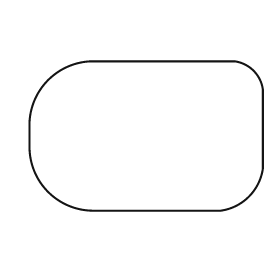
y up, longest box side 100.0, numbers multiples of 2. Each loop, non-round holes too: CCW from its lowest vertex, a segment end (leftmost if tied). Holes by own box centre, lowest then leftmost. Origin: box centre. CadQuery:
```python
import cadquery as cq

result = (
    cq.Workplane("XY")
    .moveTo(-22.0, -32.0)
    .lineTo(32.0, -32.0)
    .threePointArc((44.0, -26.0), (50.0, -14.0))
    .lineTo(50.0, 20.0)
    .threePointArc((46.0, 28.0), (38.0, 32.0))
    .lineTo(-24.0, 32.0)
    .threePointArc((-42.0, 24.0), (-50.0, 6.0))
    .lineTo(-50.0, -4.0)
    .threePointArc((-42.0, -24.0), (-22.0, -32.0))
    .close()
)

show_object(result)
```